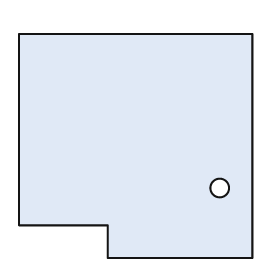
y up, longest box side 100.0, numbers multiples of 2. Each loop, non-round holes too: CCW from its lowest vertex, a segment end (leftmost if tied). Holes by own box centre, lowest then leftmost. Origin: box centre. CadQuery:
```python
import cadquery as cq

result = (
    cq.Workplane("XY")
    .moveTo(-12.0, -48.0)
    .lineTo(50.0, -48.0)
    .lineTo(50.0, 48.0)
    .lineTo(-50.0, 48.0)
    .lineTo(-50.0, -34.0)
    .lineTo(-12.0, -34.0)
    .close()
    .moveTo(36.0, -18.0)
    .circle(4.0)
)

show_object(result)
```